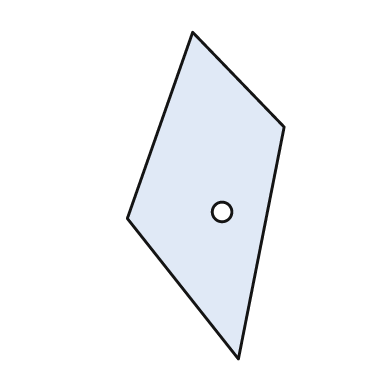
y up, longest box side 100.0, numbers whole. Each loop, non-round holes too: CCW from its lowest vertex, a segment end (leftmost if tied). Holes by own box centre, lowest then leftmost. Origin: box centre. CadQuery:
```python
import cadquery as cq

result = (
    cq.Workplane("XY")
    .moveTo(10.0, -50.0)
    .lineTo(24.0, 21.0)
    .lineTo(-4.0, 50.0)
    .lineTo(-24.0, -7.0)
    .close()
    .moveTo(5.0, -5.0)
    .circle(3.0)
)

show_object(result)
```